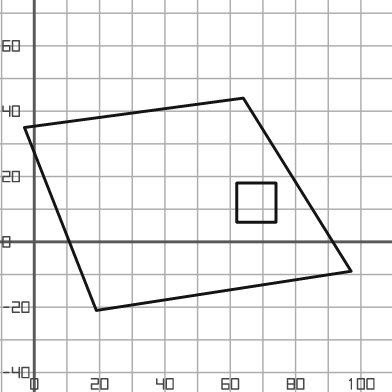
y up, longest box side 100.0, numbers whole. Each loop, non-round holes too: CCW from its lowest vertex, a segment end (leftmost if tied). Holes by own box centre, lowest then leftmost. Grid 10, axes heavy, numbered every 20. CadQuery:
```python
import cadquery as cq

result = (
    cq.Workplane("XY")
    .moveTo(19.0, -21.0)
    .lineTo(97.0, -9.0)
    .lineTo(64.0, 44.0)
    .lineTo(-3.0, 35.0)
    .close()
    .moveTo(62.0, 6.0)
    .lineTo(74.0, 6.0)
    .lineTo(74.0, 18.0)
    .lineTo(62.0, 18.0)
    .close()
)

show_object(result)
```